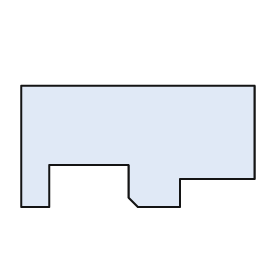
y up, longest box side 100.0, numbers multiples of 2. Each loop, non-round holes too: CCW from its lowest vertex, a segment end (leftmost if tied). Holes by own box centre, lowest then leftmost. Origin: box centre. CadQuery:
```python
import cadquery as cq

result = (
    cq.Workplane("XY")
    .moveTo(-50.0, -26.0)
    .lineTo(-38.0, -26.0)
    .lineTo(-38.0, -8.0)
    .lineTo(-4.0, -8.0)
    .lineTo(-4.0, -22.0)
    .lineTo(0.0, -26.0)
    .lineTo(18.0, -26.0)
    .lineTo(18.0, -14.0)
    .lineTo(50.0, -14.0)
    .lineTo(50.0, 26.0)
    .lineTo(-50.0, 26.0)
    .close()
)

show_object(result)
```